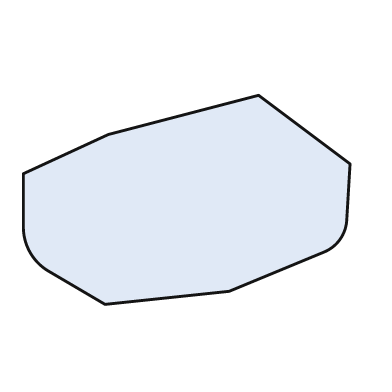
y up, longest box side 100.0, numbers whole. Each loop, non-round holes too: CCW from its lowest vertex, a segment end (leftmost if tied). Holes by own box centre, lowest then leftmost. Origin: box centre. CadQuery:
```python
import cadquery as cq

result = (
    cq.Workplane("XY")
    .moveTo(-25.0, -32.0)
    .lineTo(13.0, -28.0)
    .lineTo(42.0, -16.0)
    .threePointArc((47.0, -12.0), (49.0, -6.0))
    .lineTo(50.0, 11.0)
    .lineTo(22.0, 32.0)
    .lineTo(-24.0, 20.0)
    .lineTo(-50.0, 8.0)
    .lineTo(-50.0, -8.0)
    .threePointArc((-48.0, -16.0), (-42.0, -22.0))
    .close()
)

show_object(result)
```